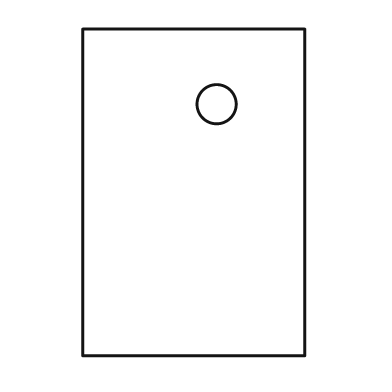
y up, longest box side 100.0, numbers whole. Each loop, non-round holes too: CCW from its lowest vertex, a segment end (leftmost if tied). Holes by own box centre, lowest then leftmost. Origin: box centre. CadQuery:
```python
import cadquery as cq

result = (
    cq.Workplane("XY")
    .moveTo(-34.0, -50.0)
    .lineTo(34.0, -50.0)
    .lineTo(34.0, 50.0)
    .lineTo(-34.0, 50.0)
    .close()
    .moveTo(7.0, 27.0)
    .circle(6.0)
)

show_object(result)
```